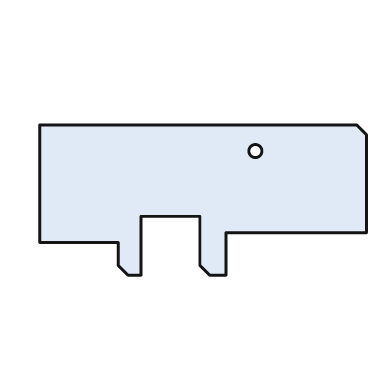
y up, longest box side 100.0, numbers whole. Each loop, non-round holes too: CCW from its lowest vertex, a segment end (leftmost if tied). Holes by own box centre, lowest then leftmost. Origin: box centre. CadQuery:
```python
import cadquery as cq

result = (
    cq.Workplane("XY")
    .moveTo(-23.0, -23.0)
    .lineTo(-19.0, -23.0)
    .lineTo(-19.0, -5.0)
    .lineTo(-1.0, -5.0)
    .lineTo(-1.0, -20.0)
    .lineTo(2.0, -23.0)
    .lineTo(7.0, -23.0)
    .lineTo(7.0, -10.0)
    .lineTo(50.0, -10.0)
    .lineTo(50.0, 20.0)
    .lineTo(47.0, 23.0)
    .lineTo(-50.0, 23.0)
    .lineTo(-50.0, -13.0)
    .lineTo(-26.0, -13.0)
    .lineTo(-26.0, -20.0)
    .close()
    .moveTo(16.0, 15.0)
    .circle(2.0)
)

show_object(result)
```